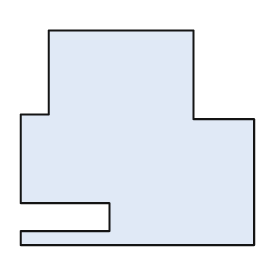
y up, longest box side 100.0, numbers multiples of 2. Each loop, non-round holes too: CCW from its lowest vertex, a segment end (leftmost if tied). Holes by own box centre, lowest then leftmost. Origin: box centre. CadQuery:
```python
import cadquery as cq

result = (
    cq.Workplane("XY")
    .moveTo(-50.0, -46.0)
    .lineTo(50.0, -46.0)
    .lineTo(50.0, 8.0)
    .lineTo(24.0, 8.0)
    .lineTo(24.0, 46.0)
    .lineTo(-38.0, 46.0)
    .lineTo(-38.0, 10.0)
    .lineTo(-50.0, 10.0)
    .lineTo(-50.0, -28.0)
    .lineTo(-12.0, -28.0)
    .lineTo(-12.0, -40.0)
    .lineTo(-50.0, -40.0)
    .close()
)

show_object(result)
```